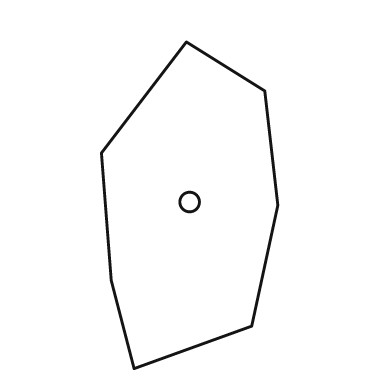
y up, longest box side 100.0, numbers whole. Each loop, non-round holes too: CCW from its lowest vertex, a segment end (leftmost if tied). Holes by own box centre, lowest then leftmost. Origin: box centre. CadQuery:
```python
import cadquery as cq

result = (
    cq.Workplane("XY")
    .moveTo(-17.0, -50.0)
    .lineTo(19.0, -37.0)
    .lineTo(27.0, 0.0)
    .lineTo(23.0, 35.0)
    .lineTo(-1.0, 50.0)
    .lineTo(-27.0, 16.0)
    .lineTo(-24.0, -23.0)
    .close()
    .moveTo(0.0, 1.0)
    .circle(3.0)
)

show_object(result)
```